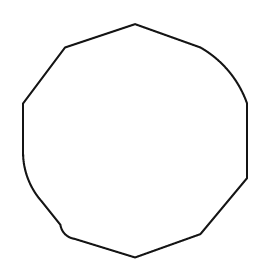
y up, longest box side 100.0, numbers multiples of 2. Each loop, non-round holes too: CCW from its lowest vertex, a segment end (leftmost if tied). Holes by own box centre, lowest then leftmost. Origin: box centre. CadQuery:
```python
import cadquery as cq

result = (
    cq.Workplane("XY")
    .moveTo(0.0, -50.0)
    .lineTo(28.0, -40.0)
    .lineTo(48.0, -16.0)
    .lineTo(48.0, 16.0)
    .threePointArc((40.0, 30.0), (28.0, 40.0))
    .lineTo(0.0, 50.0)
    .lineTo(-30.0, 40.0)
    .lineTo(-48.0, 16.0)
    .lineTo(-48.0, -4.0)
    .threePointArc((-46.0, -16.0), (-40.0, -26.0))
    .lineTo(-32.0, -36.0)
    .threePointArc((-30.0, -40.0), (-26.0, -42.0))
    .close()
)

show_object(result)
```